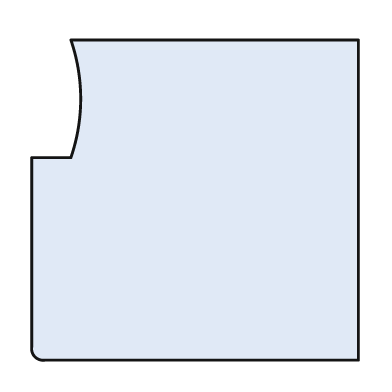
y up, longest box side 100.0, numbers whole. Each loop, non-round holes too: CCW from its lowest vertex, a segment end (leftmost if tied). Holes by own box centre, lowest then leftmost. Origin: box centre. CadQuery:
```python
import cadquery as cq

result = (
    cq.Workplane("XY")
    .moveTo(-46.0, -49.0)
    .lineTo(50.0, -49.0)
    .lineTo(50.0, 49.0)
    .lineTo(-38.0, 49.0)
    .threePointArc((-35.0, 31.0), (-38.0, 13.0))
    .lineTo(-50.0, 13.0)
    .lineTo(-50.0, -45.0)
    .threePointArc((-49.0, -48.0), (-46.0, -49.0))
    .close()
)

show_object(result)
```